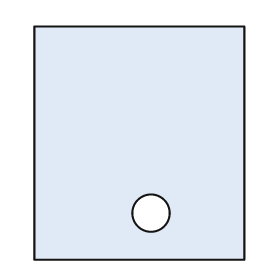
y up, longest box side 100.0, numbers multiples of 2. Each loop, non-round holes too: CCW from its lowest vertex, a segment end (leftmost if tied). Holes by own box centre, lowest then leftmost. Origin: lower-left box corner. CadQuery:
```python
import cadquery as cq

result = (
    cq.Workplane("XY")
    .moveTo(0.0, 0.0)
    .lineTo(90.0, 0.0)
    .lineTo(90.0, 100.0)
    .lineTo(0.0, 100.0)
    .close()
    .moveTo(50.0, 20.0)
    .circle(8.0)
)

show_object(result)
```